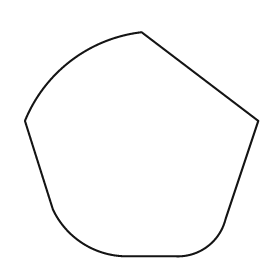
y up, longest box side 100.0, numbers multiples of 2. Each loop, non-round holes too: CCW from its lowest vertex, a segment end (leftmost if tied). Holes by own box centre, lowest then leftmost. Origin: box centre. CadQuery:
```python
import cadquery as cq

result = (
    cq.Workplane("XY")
    .moveTo(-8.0, -48.0)
    .lineTo(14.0, -48.0)
    .threePointArc((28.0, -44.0), (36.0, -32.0))
    .lineTo(50.0, 10.0)
    .lineTo(0.0, 48.0)
    .threePointArc((-30.0, 36.0), (-50.0, 10.0))
    .lineTo(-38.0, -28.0)
    .threePointArc((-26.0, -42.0), (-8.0, -48.0))
    .close()
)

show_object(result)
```